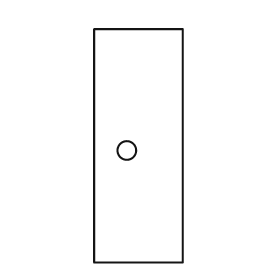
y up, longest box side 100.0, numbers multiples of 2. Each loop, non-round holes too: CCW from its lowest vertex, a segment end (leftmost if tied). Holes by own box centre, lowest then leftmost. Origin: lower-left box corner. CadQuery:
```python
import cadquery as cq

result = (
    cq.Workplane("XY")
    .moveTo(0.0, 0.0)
    .lineTo(38.0, 0.0)
    .lineTo(38.0, 100.0)
    .lineTo(0.0, 100.0)
    .close()
    .moveTo(14.0, 48.0)
    .circle(4.0)
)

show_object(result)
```